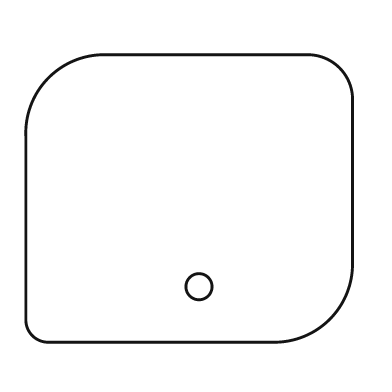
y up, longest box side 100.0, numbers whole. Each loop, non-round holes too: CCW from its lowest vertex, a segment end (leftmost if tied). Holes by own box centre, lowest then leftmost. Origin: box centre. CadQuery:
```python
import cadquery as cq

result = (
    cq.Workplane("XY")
    .moveTo(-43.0, -44.0)
    .lineTo(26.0, -44.0)
    .threePointArc((43.0, -37.0), (50.0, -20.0))
    .lineTo(50.0, 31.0)
    .threePointArc((46.0, 40.0), (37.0, 44.0))
    .lineTo(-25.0, 44.0)
    .threePointArc((-43.0, 37.0), (-50.0, 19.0))
    .lineTo(-50.0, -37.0)
    .threePointArc((-48.0, -42.0), (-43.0, -44.0))
    .close()
    .moveTo(3.0, -27.0)
    .circle(4.0)
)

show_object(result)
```